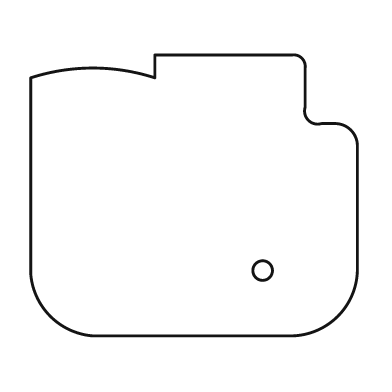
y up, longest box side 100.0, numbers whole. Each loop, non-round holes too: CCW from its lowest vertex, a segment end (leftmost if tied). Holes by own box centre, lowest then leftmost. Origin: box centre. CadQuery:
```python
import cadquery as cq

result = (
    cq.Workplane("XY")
    .moveTo(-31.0, -43.0)
    .lineTo(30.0, -43.0)
    .threePointArc((44.0, -37.0), (50.0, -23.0))
    .lineTo(50.0, 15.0)
    .threePointArc((48.0, 20.0), (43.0, 22.0))
    .lineTo(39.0, 22.0)
    .threePointArc((35.0, 23.0), (34.0, 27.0))
    .lineTo(34.0, 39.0)
    .threePointArc((33.0, 42.0), (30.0, 43.0))
    .lineTo(-12.0, 43.0)
    .lineTo(-12.0, 36.0)
    .threePointArc((-31.0, 39.0), (-50.0, 36.0))
    .lineTo(-50.0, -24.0)
    .threePointArc((-44.0, -37.0), (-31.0, -43.0))
    .close()
    .moveTo(21.0, -23.0)
    .circle(3.0)
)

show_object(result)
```